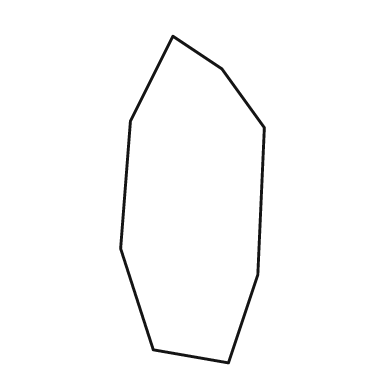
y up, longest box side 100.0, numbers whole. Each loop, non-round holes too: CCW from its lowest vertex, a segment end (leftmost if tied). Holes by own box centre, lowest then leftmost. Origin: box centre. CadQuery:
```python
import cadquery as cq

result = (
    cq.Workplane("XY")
    .moveTo(11.0, -50.0)
    .lineTo(20.0, -23.0)
    .lineTo(22.0, 22.0)
    .lineTo(9.0, 40.0)
    .lineTo(-6.0, 50.0)
    .lineTo(-19.0, 24.0)
    .lineTo(-22.0, -15.0)
    .lineTo(-12.0, -46.0)
    .close()
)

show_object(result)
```